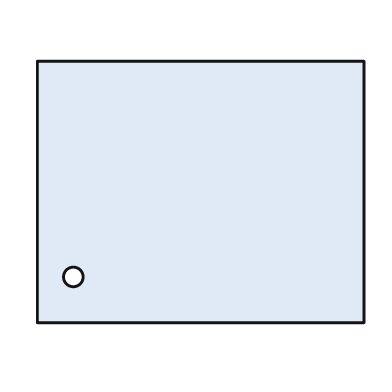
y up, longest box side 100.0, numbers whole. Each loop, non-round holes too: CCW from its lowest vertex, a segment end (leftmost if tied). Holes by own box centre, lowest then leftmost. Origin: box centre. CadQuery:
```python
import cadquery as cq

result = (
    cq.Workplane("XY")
    .moveTo(-50.0, -40.0)
    .lineTo(50.0, -40.0)
    .lineTo(50.0, 40.0)
    .lineTo(-50.0, 40.0)
    .close()
    .moveTo(-39.0, -26.0)
    .circle(3.0)
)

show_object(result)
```